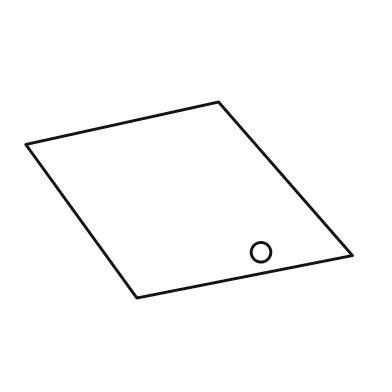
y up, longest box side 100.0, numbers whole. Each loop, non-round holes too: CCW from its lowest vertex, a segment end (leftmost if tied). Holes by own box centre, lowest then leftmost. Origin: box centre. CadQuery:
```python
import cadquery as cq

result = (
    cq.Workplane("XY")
    .moveTo(-16.0, -30.0)
    .lineTo(50.0, -17.0)
    .lineTo(9.0, 30.0)
    .lineTo(-50.0, 17.0)
    .close()
    .moveTo(22.0, -16.0)
    .circle(3.0)
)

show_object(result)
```